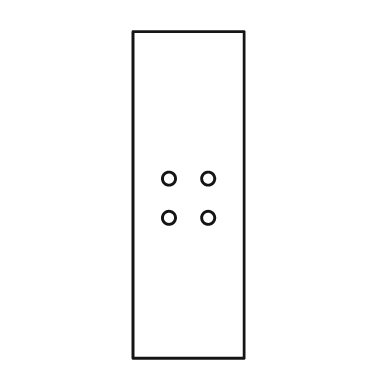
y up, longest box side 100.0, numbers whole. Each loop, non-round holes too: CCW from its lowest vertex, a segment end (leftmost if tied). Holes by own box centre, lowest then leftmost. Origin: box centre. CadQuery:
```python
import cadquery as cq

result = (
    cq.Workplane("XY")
    .moveTo(-17.0, -50.0)
    .lineTo(17.0, -50.0)
    .lineTo(17.0, 50.0)
    .lineTo(-17.0, 50.0)
    .close()
    .moveTo(-6.0, -7.0)
    .circle(2.0)
    .moveTo(6.0, -7.0)
    .circle(2.0)
    .moveTo(-6.0, 5.0)
    .circle(2.0)
    .moveTo(6.0, 5.0)
    .circle(2.0)
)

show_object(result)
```